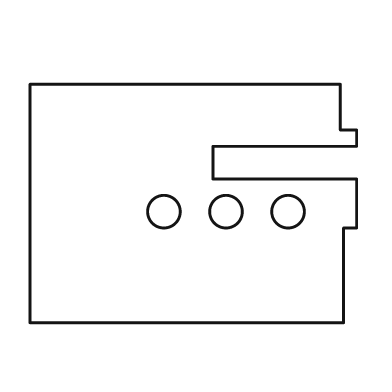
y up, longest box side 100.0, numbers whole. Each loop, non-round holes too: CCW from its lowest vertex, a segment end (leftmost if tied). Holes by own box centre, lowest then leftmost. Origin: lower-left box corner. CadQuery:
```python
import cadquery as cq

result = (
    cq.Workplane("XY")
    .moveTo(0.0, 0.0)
    .lineTo(96.0, 0.0)
    .lineTo(96.0, 29.0)
    .lineTo(100.0, 29.0)
    .lineTo(100.0, 44.0)
    .lineTo(56.0, 44.0)
    .lineTo(56.0, 54.0)
    .lineTo(100.0, 54.0)
    .lineTo(100.0, 59.0)
    .lineTo(95.0, 59.0)
    .lineTo(95.0, 73.0)
    .lineTo(0.0, 73.0)
    .close()
    .moveTo(41.0, 34.0)
    .circle(5.0)
    .moveTo(60.0, 34.0)
    .circle(5.0)
    .moveTo(79.0, 34.0)
    .circle(5.0)
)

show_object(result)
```